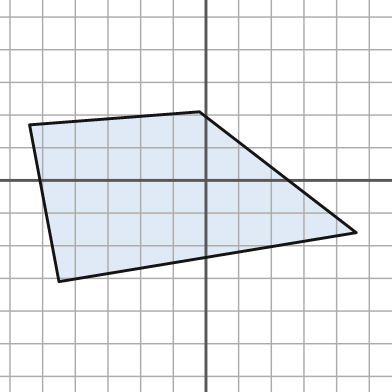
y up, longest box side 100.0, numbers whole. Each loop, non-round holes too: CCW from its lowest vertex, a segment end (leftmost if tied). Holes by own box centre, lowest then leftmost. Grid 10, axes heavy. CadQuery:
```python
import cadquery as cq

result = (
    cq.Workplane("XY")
    .moveTo(-45.0, -31.0)
    .lineTo(46.0, -16.0)
    .lineTo(-2.0, 21.0)
    .lineTo(-54.0, 17.0)
    .close()
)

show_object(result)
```